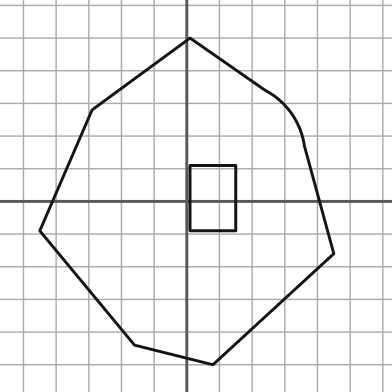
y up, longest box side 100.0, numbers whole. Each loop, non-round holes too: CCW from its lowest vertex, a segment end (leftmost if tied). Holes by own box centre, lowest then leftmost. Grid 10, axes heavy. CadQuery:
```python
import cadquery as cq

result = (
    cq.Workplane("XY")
    .moveTo(8.0, -50.0)
    .lineTo(45.0, -16.0)
    .lineTo(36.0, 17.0)
    .threePointArc((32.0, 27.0), (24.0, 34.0))
    .lineTo(1.0, 50.0)
    .lineTo(-29.0, 28.0)
    .lineTo(-45.0, -9.0)
    .lineTo(-16.0, -44.0)
    .close()
    .moveTo(1.0, -9.0)
    .lineTo(15.0, -9.0)
    .lineTo(15.0, 11.0)
    .lineTo(1.0, 11.0)
    .close()
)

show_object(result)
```